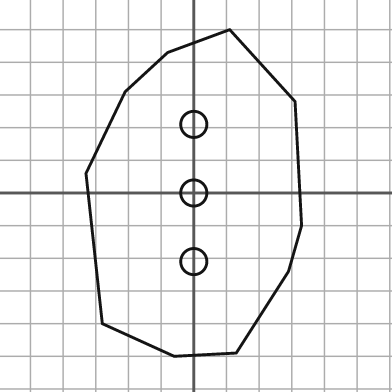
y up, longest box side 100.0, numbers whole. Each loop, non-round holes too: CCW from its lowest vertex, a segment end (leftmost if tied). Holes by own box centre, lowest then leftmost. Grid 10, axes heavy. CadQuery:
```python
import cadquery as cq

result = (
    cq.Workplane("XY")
    .moveTo(-6.0, -50.0)
    .lineTo(13.0, -49.0)
    .lineTo(29.0, -24.0)
    .lineTo(33.0, -10.0)
    .lineTo(31.0, 28.0)
    .lineTo(11.0, 50.0)
    .lineTo(-8.0, 43.0)
    .lineTo(-21.0, 31.0)
    .lineTo(-33.0, 6.0)
    .lineTo(-28.0, -40.0)
    .close()
    .moveTo(0.0, -21.0)
    .circle(4.0)
    .moveTo(0.0, 0.0)
    .circle(4.0)
    .moveTo(0.0, 21.0)
    .circle(4.0)
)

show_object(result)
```